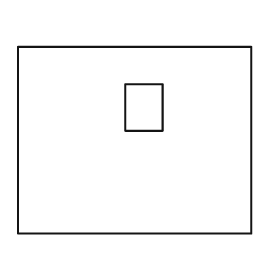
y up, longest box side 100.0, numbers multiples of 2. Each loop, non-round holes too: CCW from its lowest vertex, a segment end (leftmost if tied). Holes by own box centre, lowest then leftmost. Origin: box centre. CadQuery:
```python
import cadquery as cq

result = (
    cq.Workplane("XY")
    .moveTo(-50.0, -40.0)
    .lineTo(50.0, -40.0)
    .lineTo(50.0, 40.0)
    .lineTo(-50.0, 40.0)
    .close()
    .moveTo(-4.0, 4.0)
    .lineTo(12.0, 4.0)
    .lineTo(12.0, 24.0)
    .lineTo(-4.0, 24.0)
    .close()
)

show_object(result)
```